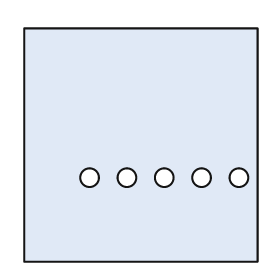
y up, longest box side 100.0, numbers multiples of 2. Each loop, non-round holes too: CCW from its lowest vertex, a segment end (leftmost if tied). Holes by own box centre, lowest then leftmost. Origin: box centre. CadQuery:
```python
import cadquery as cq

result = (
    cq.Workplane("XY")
    .moveTo(-50.0, -50.0)
    .lineTo(50.0, -50.0)
    .lineTo(50.0, 50.0)
    .lineTo(-50.0, 50.0)
    .close()
    .moveTo(-22.0, -14.0)
    .circle(4.0)
    .moveTo(-6.0, -14.0)
    .circle(4.0)
    .moveTo(10.0, -14.0)
    .circle(4.0)
    .moveTo(26.0, -14.0)
    .circle(4.0)
    .moveTo(42.0, -14.0)
    .circle(4.0)
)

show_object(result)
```